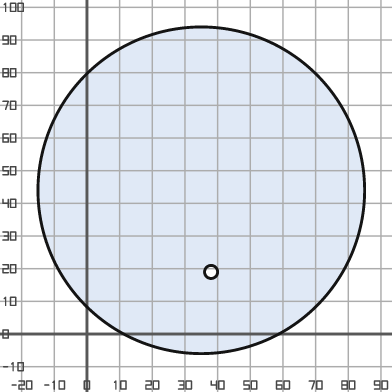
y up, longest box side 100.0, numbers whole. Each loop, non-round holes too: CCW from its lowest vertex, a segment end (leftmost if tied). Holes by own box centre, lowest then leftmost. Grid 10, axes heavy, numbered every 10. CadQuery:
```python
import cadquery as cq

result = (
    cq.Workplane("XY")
    .moveTo(35.0, 44.0)
    .circle(50.0)
    .moveTo(38.0, 19.0)
    .circle(2.0)
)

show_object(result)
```